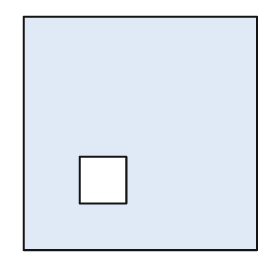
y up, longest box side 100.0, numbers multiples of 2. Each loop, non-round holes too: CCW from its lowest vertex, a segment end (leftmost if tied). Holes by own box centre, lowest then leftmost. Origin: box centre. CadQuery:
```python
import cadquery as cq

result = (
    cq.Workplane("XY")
    .moveTo(-50.0, -50.0)
    .lineTo(50.0, -50.0)
    .lineTo(50.0, 50.0)
    .lineTo(-50.0, 50.0)
    .close()
    .moveTo(-26.0, -30.0)
    .lineTo(-6.0, -30.0)
    .lineTo(-6.0, -10.0)
    .lineTo(-26.0, -10.0)
    .close()
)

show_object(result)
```